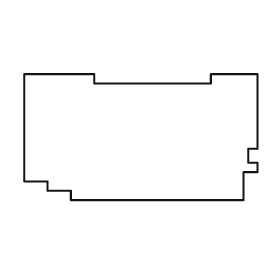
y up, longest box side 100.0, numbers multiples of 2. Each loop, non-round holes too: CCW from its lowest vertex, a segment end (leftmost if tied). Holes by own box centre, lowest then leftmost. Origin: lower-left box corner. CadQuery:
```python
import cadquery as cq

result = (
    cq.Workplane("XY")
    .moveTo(20.0, 0.0)
    .lineTo(94.0, 0.0)
    .lineTo(94.0, 12.0)
    .lineTo(100.0, 12.0)
    .lineTo(100.0, 16.0)
    .lineTo(96.0, 16.0)
    .lineTo(96.0, 22.0)
    .lineTo(100.0, 22.0)
    .lineTo(100.0, 54.0)
    .lineTo(80.0, 54.0)
    .lineTo(80.0, 50.0)
    .lineTo(30.0, 50.0)
    .lineTo(30.0, 54.0)
    .lineTo(0.0, 54.0)
    .lineTo(0.0, 8.0)
    .lineTo(10.0, 8.0)
    .lineTo(10.0, 4.0)
    .lineTo(20.0, 4.0)
    .close()
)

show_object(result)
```